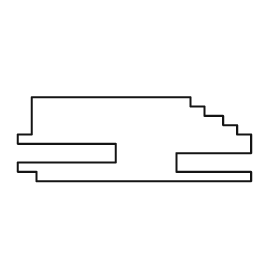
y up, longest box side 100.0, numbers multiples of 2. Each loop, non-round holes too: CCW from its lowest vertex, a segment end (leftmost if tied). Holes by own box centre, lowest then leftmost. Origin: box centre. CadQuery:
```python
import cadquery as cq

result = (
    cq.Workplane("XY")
    .moveTo(-42.0, -18.0)
    .lineTo(50.0, -18.0)
    .lineTo(50.0, -14.0)
    .lineTo(18.0, -14.0)
    .lineTo(18.0, -6.0)
    .lineTo(50.0, -6.0)
    .lineTo(50.0, 2.0)
    .lineTo(44.0, 2.0)
    .lineTo(44.0, 6.0)
    .lineTo(38.0, 6.0)
    .lineTo(38.0, 10.0)
    .lineTo(30.0, 10.0)
    .lineTo(30.0, 14.0)
    .lineTo(24.0, 14.0)
    .lineTo(24.0, 18.0)
    .lineTo(-44.0, 18.0)
    .lineTo(-44.0, 2.0)
    .lineTo(-50.0, 2.0)
    .lineTo(-50.0, -2.0)
    .lineTo(-8.0, -2.0)
    .lineTo(-8.0, -10.0)
    .lineTo(-50.0, -10.0)
    .lineTo(-50.0, -14.0)
    .lineTo(-42.0, -14.0)
    .close()
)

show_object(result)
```